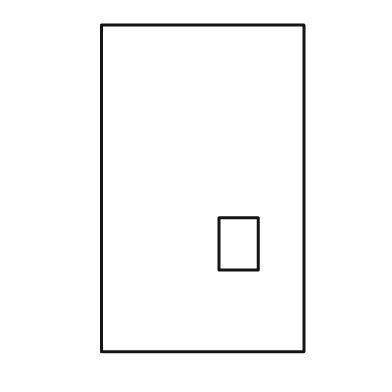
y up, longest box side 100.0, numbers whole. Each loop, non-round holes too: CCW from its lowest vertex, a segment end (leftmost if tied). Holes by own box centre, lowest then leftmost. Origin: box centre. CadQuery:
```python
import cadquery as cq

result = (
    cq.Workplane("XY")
    .moveTo(-31.0, -50.0)
    .lineTo(31.0, -50.0)
    .lineTo(31.0, 50.0)
    .lineTo(-31.0, 50.0)
    .close()
    .moveTo(5.0, -25.0)
    .lineTo(17.0, -25.0)
    .lineTo(17.0, -9.0)
    .lineTo(5.0, -9.0)
    .close()
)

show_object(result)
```